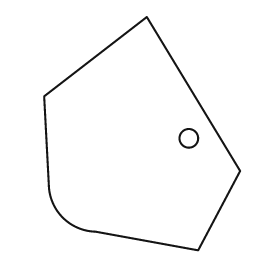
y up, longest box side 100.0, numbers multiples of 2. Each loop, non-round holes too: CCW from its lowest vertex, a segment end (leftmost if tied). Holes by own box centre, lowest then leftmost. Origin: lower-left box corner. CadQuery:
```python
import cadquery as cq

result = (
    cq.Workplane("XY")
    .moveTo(66.0, 0.0)
    .lineTo(84.0, 34.0)
    .lineTo(44.0, 100.0)
    .lineTo(0.0, 66.0)
    .lineTo(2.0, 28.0)
    .threePointArc((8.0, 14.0), (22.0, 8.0))
    .close()
    .moveTo(62.0, 48.0)
    .circle(4.0)
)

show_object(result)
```